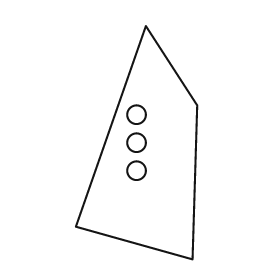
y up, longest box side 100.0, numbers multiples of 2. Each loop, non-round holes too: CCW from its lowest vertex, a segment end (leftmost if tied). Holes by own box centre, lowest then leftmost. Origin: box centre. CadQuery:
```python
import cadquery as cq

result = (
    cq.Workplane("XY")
    .moveTo(24.0, -50.0)
    .lineTo(26.0, 16.0)
    .lineTo(4.0, 50.0)
    .lineTo(-26.0, -36.0)
    .close()
    .moveTo(0.0, -12.0)
    .circle(4.0)
    .moveTo(0.0, 0.0)
    .circle(4.0)
    .moveTo(0.0, 12.0)
    .circle(4.0)
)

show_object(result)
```